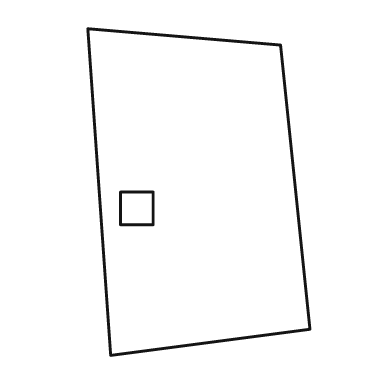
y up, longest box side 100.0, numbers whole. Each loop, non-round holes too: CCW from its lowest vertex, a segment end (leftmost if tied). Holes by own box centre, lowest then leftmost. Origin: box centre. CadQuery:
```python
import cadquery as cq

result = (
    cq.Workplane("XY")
    .moveTo(-27.0, -50.0)
    .lineTo(34.0, -42.0)
    .lineTo(25.0, 45.0)
    .lineTo(-34.0, 50.0)
    .close()
    .moveTo(-24.0, -10.0)
    .lineTo(-14.0, -10.0)
    .lineTo(-14.0, 0.0)
    .lineTo(-24.0, 0.0)
    .close()
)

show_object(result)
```